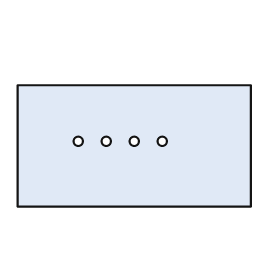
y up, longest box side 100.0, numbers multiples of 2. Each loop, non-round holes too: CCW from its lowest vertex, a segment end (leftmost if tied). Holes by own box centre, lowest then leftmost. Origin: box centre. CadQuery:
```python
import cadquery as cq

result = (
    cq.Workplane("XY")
    .moveTo(-50.0, -26.0)
    .lineTo(50.0, -26.0)
    .lineTo(50.0, 26.0)
    .lineTo(-50.0, 26.0)
    .close()
    .moveTo(-24.0, 2.0)
    .circle(2.0)
    .moveTo(-12.0, 2.0)
    .circle(2.0)
    .moveTo(0.0, 2.0)
    .circle(2.0)
    .moveTo(12.0, 2.0)
    .circle(2.0)
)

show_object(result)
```